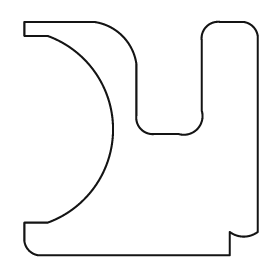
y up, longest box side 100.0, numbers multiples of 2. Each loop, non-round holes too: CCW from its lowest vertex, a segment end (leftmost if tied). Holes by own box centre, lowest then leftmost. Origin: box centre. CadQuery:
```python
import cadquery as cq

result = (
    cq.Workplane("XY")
    .moveTo(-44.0, -50.0)
    .lineTo(38.0, -50.0)
    .lineTo(38.0, -40.0)
    .threePointArc((44.0, -42.0), (50.0, -40.0))
    .lineTo(50.0, 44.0)
    .threePointArc((48.0, 48.0), (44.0, 50.0))
    .lineTo(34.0, 50.0)
    .threePointArc((28.0, 48.0), (26.0, 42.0))
    .lineTo(26.0, 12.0)
    .threePointArc((24.0, 4.0), (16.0, 2.0))
    .lineTo(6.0, 2.0)
    .threePointArc((0.0, 4.0), (-2.0, 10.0))
    .lineTo(-2.0, 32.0)
    .threePointArc((-8.0, 44.0), (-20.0, 50.0))
    .lineTo(-50.0, 50.0)
    .lineTo(-50.0, 44.0)
    .lineTo(-40.0, 44.0)
    .threePointArc((-12.0, 4.0), (-40.0, -36.0))
    .lineTo(-50.0, -36.0)
    .lineTo(-50.0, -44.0)
    .threePointArc((-48.0, -48.0), (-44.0, -50.0))
    .close()
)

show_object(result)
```